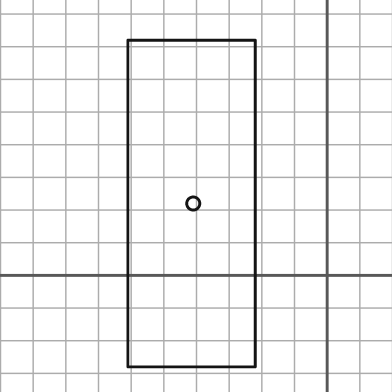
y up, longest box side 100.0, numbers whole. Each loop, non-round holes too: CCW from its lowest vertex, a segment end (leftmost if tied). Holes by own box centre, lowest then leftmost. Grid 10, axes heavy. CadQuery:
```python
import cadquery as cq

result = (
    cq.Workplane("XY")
    .moveTo(-61.0, -28.0)
    .lineTo(-22.0, -28.0)
    .lineTo(-22.0, 72.0)
    .lineTo(-61.0, 72.0)
    .close()
    .moveTo(-41.0, 22.0)
    .circle(2.0)
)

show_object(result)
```